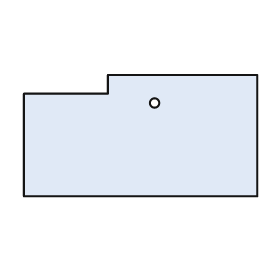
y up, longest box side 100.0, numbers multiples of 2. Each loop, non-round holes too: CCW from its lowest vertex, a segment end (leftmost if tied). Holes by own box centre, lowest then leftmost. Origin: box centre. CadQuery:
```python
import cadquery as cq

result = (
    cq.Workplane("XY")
    .moveTo(-50.0, -26.0)
    .lineTo(50.0, -26.0)
    .lineTo(50.0, 26.0)
    .lineTo(-14.0, 26.0)
    .lineTo(-14.0, 18.0)
    .lineTo(-50.0, 18.0)
    .close()
    .moveTo(6.0, 14.0)
    .circle(2.0)
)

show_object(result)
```